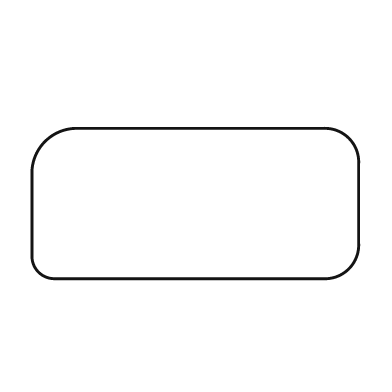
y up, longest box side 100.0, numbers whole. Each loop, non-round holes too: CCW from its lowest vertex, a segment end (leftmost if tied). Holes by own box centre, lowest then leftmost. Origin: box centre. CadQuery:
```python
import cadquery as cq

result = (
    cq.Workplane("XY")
    .moveTo(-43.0, -23.0)
    .lineTo(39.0, -23.0)
    .threePointArc((47.0, -20.0), (50.0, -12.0))
    .lineTo(50.0, 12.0)
    .threePointArc((47.0, 20.0), (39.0, 23.0))
    .lineTo(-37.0, 23.0)
    .threePointArc((-46.0, 19.0), (-50.0, 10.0))
    .lineTo(-50.0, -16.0)
    .threePointArc((-48.0, -21.0), (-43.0, -23.0))
    .close()
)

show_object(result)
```